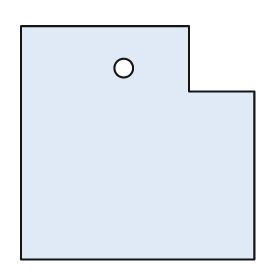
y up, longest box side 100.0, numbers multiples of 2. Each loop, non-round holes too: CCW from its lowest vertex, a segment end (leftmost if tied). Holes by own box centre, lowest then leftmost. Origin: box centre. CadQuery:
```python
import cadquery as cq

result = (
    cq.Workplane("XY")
    .moveTo(-50.0, -50.0)
    .lineTo(50.0, -50.0)
    .lineTo(50.0, 22.0)
    .lineTo(22.0, 22.0)
    .lineTo(22.0, 50.0)
    .lineTo(-50.0, 50.0)
    .close()
    .moveTo(-6.0, 32.0)
    .circle(4.0)
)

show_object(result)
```